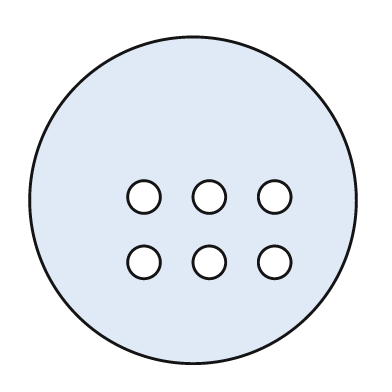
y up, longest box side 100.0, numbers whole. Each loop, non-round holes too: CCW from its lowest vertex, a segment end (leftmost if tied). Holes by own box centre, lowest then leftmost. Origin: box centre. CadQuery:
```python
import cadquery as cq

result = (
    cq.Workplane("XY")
    .moveTo(0.0, 0.0)
    .circle(50.0)
    .moveTo(-15.0, -19.0)
    .circle(5.0)
    .moveTo(5.0, -19.0)
    .circle(5.0)
    .moveTo(25.0, -19.0)
    .circle(5.0)
    .moveTo(-15.0, 1.0)
    .circle(5.0)
    .moveTo(5.0, 1.0)
    .circle(5.0)
    .moveTo(25.0, 1.0)
    .circle(5.0)
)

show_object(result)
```